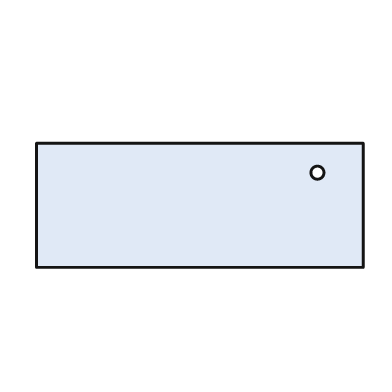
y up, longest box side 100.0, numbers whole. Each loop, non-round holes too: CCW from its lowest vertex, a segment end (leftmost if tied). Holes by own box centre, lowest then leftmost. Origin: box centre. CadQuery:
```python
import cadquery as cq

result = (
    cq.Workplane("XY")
    .moveTo(-50.0, -19.0)
    .lineTo(50.0, -19.0)
    .lineTo(50.0, 19.0)
    .lineTo(-50.0, 19.0)
    .close()
    .moveTo(36.0, 10.0)
    .circle(2.0)
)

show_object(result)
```